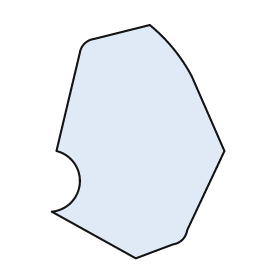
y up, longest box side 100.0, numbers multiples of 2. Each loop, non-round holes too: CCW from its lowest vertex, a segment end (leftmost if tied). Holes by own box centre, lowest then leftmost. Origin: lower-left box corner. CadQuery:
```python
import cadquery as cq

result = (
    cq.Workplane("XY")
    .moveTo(36.0, 0.0)
    .lineTo(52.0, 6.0)
    .threePointArc((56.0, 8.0), (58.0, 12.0))
    .lineTo(74.0, 46.0)
    .lineTo(60.0, 78.0)
    .threePointArc((52.0, 90.0), (42.0, 100.0))
    .lineTo(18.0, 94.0)
    .threePointArc((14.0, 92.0), (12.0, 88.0))
    .lineTo(2.0, 46.0)
    .threePointArc((12.0, 32.0), (0.0, 20.0))
    .close()
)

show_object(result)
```